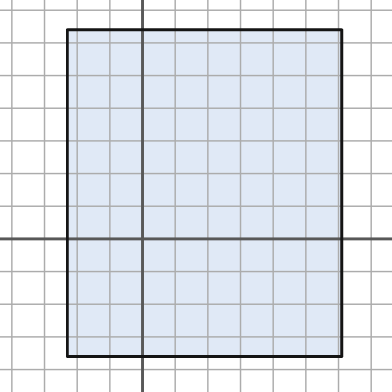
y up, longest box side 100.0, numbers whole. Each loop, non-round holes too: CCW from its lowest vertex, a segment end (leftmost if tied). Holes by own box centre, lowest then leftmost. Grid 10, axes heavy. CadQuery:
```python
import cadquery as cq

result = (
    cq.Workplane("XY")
    .moveTo(-23.0, -36.0)
    .lineTo(61.0, -36.0)
    .lineTo(61.0, 64.0)
    .lineTo(-23.0, 64.0)
    .close()
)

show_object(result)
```